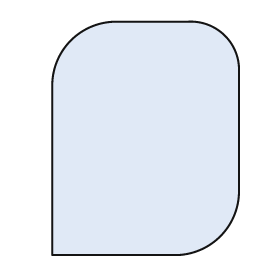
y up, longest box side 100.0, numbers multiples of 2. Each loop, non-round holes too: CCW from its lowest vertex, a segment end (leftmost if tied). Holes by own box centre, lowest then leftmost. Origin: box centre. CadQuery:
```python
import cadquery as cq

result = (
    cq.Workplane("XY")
    .moveTo(-40.0, -50.0)
    .lineTo(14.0, -50.0)
    .threePointArc((32.0, -42.0), (40.0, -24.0))
    .lineTo(40.0, 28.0)
    .threePointArc((34.0, 44.0), (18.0, 50.0))
    .lineTo(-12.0, 50.0)
    .threePointArc((-32.0, 42.0), (-40.0, 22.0))
    .close()
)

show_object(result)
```